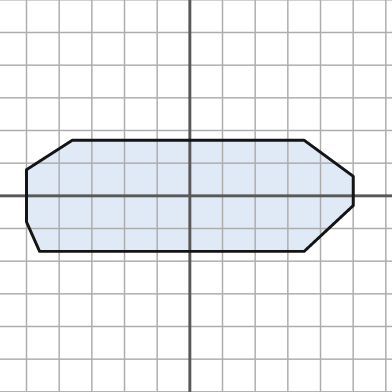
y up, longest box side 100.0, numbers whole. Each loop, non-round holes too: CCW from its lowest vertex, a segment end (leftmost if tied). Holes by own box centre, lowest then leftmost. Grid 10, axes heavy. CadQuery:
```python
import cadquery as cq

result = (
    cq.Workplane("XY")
    .moveTo(-46.0, -17.0)
    .lineTo(35.0, -17.0)
    .lineTo(50.0, -3.0)
    .lineTo(50.0, 6.0)
    .lineTo(35.0, 17.0)
    .lineTo(-36.0, 17.0)
    .lineTo(-50.0, 8.0)
    .lineTo(-50.0, -8.0)
    .close()
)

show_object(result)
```